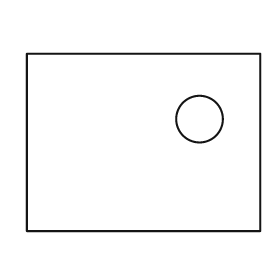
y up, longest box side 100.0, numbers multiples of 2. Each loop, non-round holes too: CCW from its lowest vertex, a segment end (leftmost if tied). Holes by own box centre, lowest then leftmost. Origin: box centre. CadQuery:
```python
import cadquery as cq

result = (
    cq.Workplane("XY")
    .moveTo(-50.0, -38.0)
    .lineTo(50.0, -38.0)
    .lineTo(50.0, 38.0)
    .lineTo(-50.0, 38.0)
    .close()
    .moveTo(24.0, 10.0)
    .circle(10.0)
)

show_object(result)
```